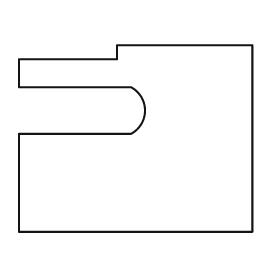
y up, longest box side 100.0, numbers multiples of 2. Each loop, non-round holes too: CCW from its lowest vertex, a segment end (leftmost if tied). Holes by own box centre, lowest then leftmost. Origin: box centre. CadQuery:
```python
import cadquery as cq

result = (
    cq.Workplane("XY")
    .moveTo(-50.0, -40.0)
    .lineTo(50.0, -40.0)
    .lineTo(50.0, 40.0)
    .lineTo(-8.0, 40.0)
    .lineTo(-8.0, 34.0)
    .lineTo(-50.0, 34.0)
    .lineTo(-50.0, 22.0)
    .lineTo(-2.0, 22.0)
    .threePointArc((4.0, 12.0), (-2.0, 2.0))
    .lineTo(-50.0, 2.0)
    .close()
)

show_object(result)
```